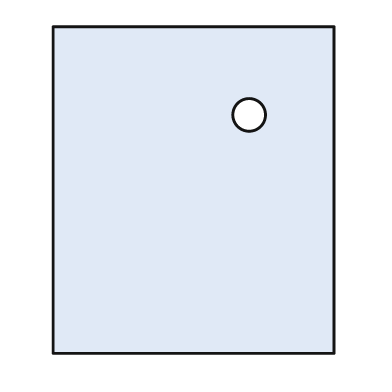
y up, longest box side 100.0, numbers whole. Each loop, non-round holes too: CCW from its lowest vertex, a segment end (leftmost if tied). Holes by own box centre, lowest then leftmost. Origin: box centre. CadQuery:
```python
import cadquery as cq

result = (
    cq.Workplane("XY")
    .moveTo(-43.0, -50.0)
    .lineTo(43.0, -50.0)
    .lineTo(43.0, 50.0)
    .lineTo(-43.0, 50.0)
    .close()
    .moveTo(17.0, 23.0)
    .circle(5.0)
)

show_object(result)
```